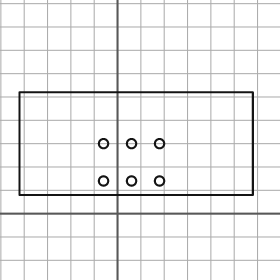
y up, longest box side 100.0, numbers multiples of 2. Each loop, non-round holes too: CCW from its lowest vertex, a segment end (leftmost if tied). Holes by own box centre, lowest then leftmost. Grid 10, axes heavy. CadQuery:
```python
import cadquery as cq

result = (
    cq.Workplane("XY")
    .moveTo(-42.0, 8.0)
    .lineTo(58.0, 8.0)
    .lineTo(58.0, 52.0)
    .lineTo(-42.0, 52.0)
    .close()
    .moveTo(-6.0, 14.0)
    .circle(2.0)
    .moveTo(6.0, 14.0)
    .circle(2.0)
    .moveTo(18.0, 14.0)
    .circle(2.0)
    .moveTo(-6.0, 30.0)
    .circle(2.0)
    .moveTo(6.0, 30.0)
    .circle(2.0)
    .moveTo(18.0, 30.0)
    .circle(2.0)
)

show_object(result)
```